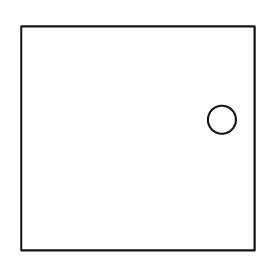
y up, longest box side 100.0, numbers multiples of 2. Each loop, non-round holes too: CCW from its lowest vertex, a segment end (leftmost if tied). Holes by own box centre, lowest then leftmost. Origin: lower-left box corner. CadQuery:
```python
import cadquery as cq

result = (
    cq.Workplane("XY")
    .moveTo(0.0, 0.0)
    .lineTo(100.0, 0.0)
    .lineTo(100.0, 96.0)
    .lineTo(0.0, 96.0)
    .close()
    .moveTo(86.0, 56.0)
    .circle(6.0)
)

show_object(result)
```